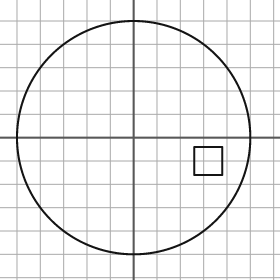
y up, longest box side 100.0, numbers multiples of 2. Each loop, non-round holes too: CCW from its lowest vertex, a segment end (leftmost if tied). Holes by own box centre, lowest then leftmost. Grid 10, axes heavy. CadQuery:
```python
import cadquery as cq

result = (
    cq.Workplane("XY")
    .moveTo(0.0, 0.0)
    .circle(50.0)
    .moveTo(26.0, -16.0)
    .lineTo(38.0, -16.0)
    .lineTo(38.0, -4.0)
    .lineTo(26.0, -4.0)
    .close()
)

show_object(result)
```